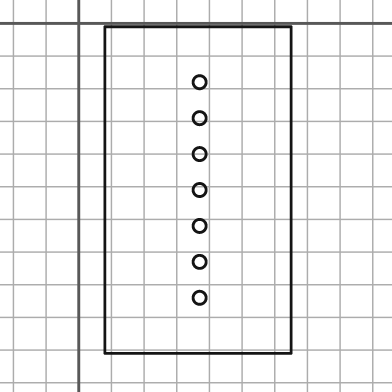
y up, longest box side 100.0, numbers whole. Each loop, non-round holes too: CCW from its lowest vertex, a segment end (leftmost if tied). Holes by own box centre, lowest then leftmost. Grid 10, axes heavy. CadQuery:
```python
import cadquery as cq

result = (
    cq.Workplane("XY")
    .moveTo(8.0, -101.0)
    .lineTo(65.0, -101.0)
    .lineTo(65.0, -1.0)
    .lineTo(8.0, -1.0)
    .close()
    .moveTo(37.0, -84.0)
    .circle(2.0)
    .moveTo(37.0, -73.0)
    .circle(2.0)
    .moveTo(37.0, -62.0)
    .circle(2.0)
    .moveTo(37.0, -51.0)
    .circle(2.0)
    .moveTo(37.0, -40.0)
    .circle(2.0)
    .moveTo(37.0, -29.0)
    .circle(2.0)
    .moveTo(37.0, -18.0)
    .circle(2.0)
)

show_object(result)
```